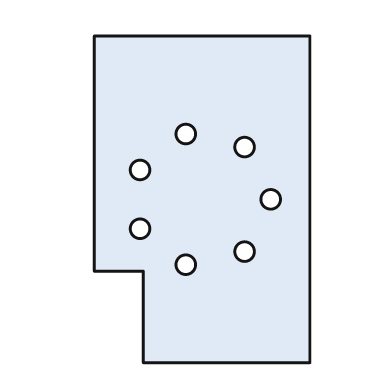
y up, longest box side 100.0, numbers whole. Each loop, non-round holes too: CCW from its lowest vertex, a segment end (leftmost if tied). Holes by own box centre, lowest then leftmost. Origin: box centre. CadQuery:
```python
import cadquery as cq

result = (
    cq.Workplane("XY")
    .moveTo(-18.0, -50.0)
    .lineTo(33.0, -50.0)
    .lineTo(33.0, 50.0)
    .lineTo(-33.0, 50.0)
    .lineTo(-33.0, -22.0)
    .lineTo(-18.0, -22.0)
    .close()
    .moveTo(-5.0, -20.0)
    .circle(3.0)
    .moveTo(13.0, -16.0)
    .circle(3.0)
    .moveTo(-19.0, -9.0)
    .circle(3.0)
    .moveTo(21.0, 0.0)
    .circle(3.0)
    .moveTo(-19.0, 9.0)
    .circle(3.0)
    .moveTo(13.0, 16.0)
    .circle(3.0)
    .moveTo(-5.0, 20.0)
    .circle(3.0)
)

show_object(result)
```